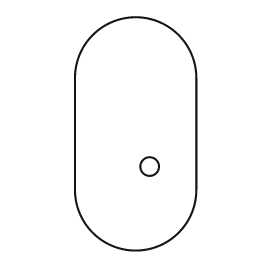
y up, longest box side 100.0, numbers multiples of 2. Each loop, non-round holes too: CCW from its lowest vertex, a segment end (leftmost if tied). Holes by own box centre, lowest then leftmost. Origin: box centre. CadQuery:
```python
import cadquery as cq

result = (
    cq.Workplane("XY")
    .moveTo(-26.0, -24.0)
    .threePointArc((0.0, -50.0), (26.0, -24.0))
    .lineTo(26.0, 24.0)
    .threePointArc((0.0, 50.0), (-26.0, 24.0))
    .close()
    .moveTo(6.0, -14.0)
    .circle(4.0)
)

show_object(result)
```